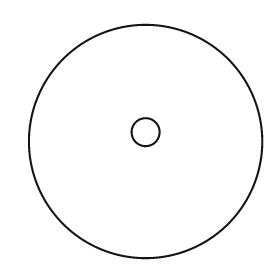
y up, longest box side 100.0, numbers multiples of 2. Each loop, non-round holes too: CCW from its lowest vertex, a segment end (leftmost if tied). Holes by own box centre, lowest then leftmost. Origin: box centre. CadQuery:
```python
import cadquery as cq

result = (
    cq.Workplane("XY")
    .moveTo(0.0, 0.0)
    .circle(50.0)
    .moveTo(0.0, 4.0)
    .circle(6.0)
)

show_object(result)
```